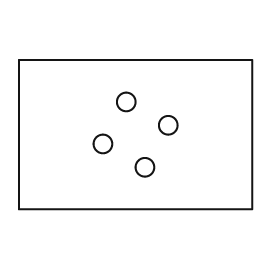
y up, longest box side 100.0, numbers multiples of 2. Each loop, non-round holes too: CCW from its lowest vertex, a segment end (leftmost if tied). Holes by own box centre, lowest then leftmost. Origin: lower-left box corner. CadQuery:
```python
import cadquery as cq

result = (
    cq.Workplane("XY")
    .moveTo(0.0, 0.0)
    .lineTo(100.0, 0.0)
    .lineTo(100.0, 64.0)
    .lineTo(0.0, 64.0)
    .close()
    .moveTo(54.0, 18.0)
    .circle(4.0)
    .moveTo(36.0, 28.0)
    .circle(4.0)
    .moveTo(64.0, 36.0)
    .circle(4.0)
    .moveTo(46.0, 46.0)
    .circle(4.0)
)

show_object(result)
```